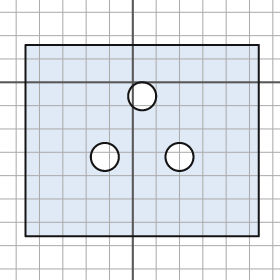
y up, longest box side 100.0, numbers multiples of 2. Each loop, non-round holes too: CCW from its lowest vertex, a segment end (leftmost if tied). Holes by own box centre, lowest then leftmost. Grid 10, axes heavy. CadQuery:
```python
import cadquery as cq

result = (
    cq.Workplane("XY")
    .moveTo(-46.0, -66.0)
    .lineTo(54.0, -66.0)
    .lineTo(54.0, 16.0)
    .lineTo(-46.0, 16.0)
    .close()
    .moveTo(-12.0, -32.0)
    .circle(6.0)
    .moveTo(20.0, -32.0)
    .circle(6.0)
    .moveTo(4.0, -6.0)
    .circle(6.0)
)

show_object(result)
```